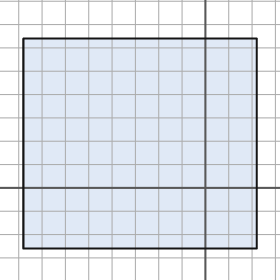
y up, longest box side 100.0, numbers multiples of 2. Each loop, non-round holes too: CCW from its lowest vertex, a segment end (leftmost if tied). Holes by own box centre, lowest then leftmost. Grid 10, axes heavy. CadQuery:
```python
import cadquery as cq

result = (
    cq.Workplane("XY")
    .moveTo(-78.0, -26.0)
    .lineTo(22.0, -26.0)
    .lineTo(22.0, 64.0)
    .lineTo(-78.0, 64.0)
    .close()
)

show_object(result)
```